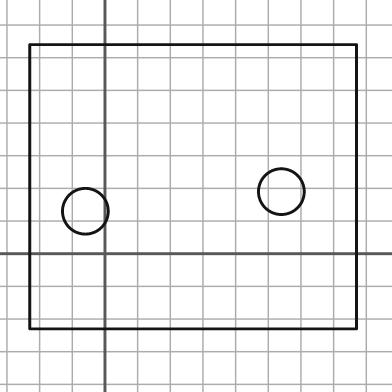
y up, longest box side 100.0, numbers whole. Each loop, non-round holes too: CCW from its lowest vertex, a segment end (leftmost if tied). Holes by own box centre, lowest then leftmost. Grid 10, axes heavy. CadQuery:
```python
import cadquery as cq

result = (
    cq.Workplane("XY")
    .moveTo(-23.0, -23.0)
    .lineTo(77.0, -23.0)
    .lineTo(77.0, 64.0)
    .lineTo(-23.0, 64.0)
    .close()
    .moveTo(-6.0, 13.0)
    .circle(7.0)
    .moveTo(54.0, 19.0)
    .circle(7.0)
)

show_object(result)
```